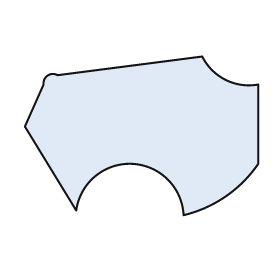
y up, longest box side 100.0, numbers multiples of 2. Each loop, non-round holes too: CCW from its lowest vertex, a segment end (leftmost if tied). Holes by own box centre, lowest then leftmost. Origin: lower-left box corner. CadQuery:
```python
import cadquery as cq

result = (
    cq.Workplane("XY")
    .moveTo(68.0, 0.0)
    .threePointArc((86.0, 8.0), (100.0, 22.0))
    .lineTo(100.0, 56.0)
    .threePointArc((86.0, 58.0), (76.0, 68.0))
    .lineTo(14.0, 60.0)
    .threePointArc((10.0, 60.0), (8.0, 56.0))
    .lineTo(0.0, 38.0)
    .lineTo(22.0, 2.0)
    .threePointArc((46.0, 22.0), (68.0, 0.0))
    .close()
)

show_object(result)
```